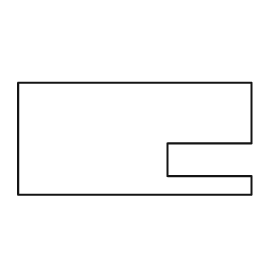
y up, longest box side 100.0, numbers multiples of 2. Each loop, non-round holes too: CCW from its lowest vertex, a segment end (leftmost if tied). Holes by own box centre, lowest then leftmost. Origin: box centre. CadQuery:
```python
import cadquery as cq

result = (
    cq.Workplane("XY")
    .moveTo(-50.0, -24.0)
    .lineTo(50.0, -24.0)
    .lineTo(50.0, -16.0)
    .lineTo(14.0, -16.0)
    .lineTo(14.0, -2.0)
    .lineTo(50.0, -2.0)
    .lineTo(50.0, 24.0)
    .lineTo(-50.0, 24.0)
    .close()
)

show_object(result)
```